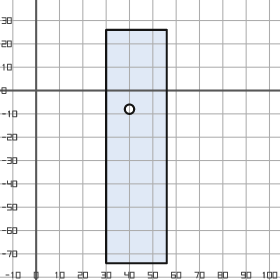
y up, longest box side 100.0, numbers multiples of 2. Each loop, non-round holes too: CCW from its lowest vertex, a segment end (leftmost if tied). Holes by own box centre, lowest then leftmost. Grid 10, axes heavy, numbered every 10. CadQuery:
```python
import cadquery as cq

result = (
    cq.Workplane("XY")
    .moveTo(30.0, -74.0)
    .lineTo(56.0, -74.0)
    .lineTo(56.0, 26.0)
    .lineTo(30.0, 26.0)
    .close()
    .moveTo(40.0, -8.0)
    .circle(2.0)
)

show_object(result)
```